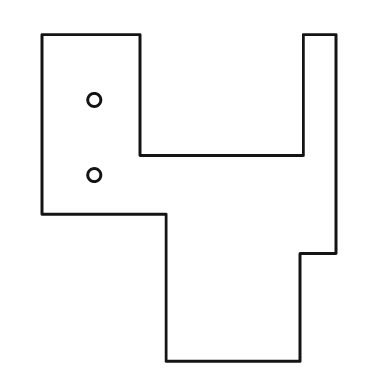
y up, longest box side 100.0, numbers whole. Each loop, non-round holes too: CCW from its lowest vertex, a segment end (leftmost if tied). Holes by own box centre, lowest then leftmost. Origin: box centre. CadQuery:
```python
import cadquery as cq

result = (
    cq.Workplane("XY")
    .moveTo(-7.0, -50.0)
    .lineTo(34.0, -50.0)
    .lineTo(34.0, -17.0)
    .lineTo(45.0, -17.0)
    .lineTo(45.0, 50.0)
    .lineTo(35.0, 50.0)
    .lineTo(35.0, 13.0)
    .lineTo(-15.0, 13.0)
    .lineTo(-15.0, 50.0)
    .lineTo(-45.0, 50.0)
    .lineTo(-45.0, -5.0)
    .lineTo(-7.0, -5.0)
    .close()
    .moveTo(-29.0, 7.0)
    .circle(2.0)
    .moveTo(-29.0, 30.0)
    .circle(2.0)
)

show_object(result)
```